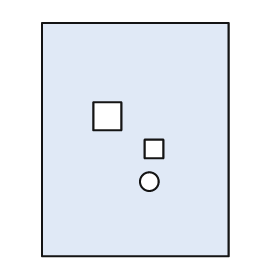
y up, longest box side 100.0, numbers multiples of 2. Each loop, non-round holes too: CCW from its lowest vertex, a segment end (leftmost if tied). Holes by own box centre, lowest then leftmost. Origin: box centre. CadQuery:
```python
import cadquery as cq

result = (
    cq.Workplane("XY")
    .moveTo(-40.0, -50.0)
    .lineTo(40.0, -50.0)
    .lineTo(40.0, 50.0)
    .lineTo(-40.0, 50.0)
    .close()
    .moveTo(6.0, -18.0)
    .circle(4.0)
    .moveTo(4.0, -8.0)
    .lineTo(12.0, -8.0)
    .lineTo(12.0, 0.0)
    .lineTo(4.0, 0.0)
    .close()
    .moveTo(-18.0, 4.0)
    .lineTo(-6.0, 4.0)
    .lineTo(-6.0, 16.0)
    .lineTo(-18.0, 16.0)
    .close()
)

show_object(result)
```